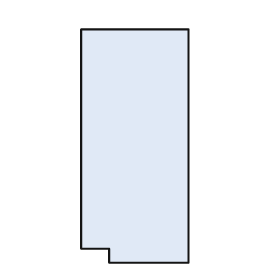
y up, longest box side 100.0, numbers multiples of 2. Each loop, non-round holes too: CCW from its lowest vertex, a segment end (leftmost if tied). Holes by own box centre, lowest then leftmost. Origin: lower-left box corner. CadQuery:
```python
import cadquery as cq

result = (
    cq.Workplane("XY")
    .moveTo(12.0, 0.0)
    .lineTo(46.0, 0.0)
    .lineTo(46.0, 100.0)
    .lineTo(0.0, 100.0)
    .lineTo(0.0, 6.0)
    .lineTo(12.0, 6.0)
    .close()
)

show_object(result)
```